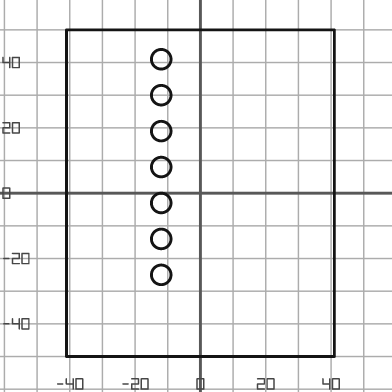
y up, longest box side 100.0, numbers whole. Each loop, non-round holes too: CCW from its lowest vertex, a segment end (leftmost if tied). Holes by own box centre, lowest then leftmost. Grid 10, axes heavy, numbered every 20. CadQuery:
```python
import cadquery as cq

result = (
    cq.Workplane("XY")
    .moveTo(-41.0, -50.0)
    .lineTo(41.0, -50.0)
    .lineTo(41.0, 50.0)
    .lineTo(-41.0, 50.0)
    .close()
    .moveTo(-12.0, -25.0)
    .circle(3.0)
    .moveTo(-12.0, -14.0)
    .circle(3.0)
    .moveTo(-12.0, -3.0)
    .circle(3.0)
    .moveTo(-12.0, 8.0)
    .circle(3.0)
    .moveTo(-12.0, 19.0)
    .circle(3.0)
    .moveTo(-12.0, 30.0)
    .circle(3.0)
    .moveTo(-12.0, 41.0)
    .circle(3.0)
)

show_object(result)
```